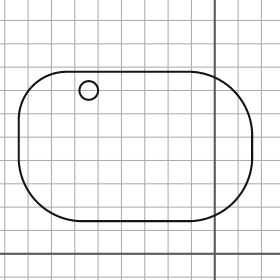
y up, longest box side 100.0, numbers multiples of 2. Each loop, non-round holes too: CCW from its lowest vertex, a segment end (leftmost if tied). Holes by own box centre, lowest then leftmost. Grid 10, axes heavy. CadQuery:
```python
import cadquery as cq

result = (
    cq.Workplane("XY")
    .moveTo(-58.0, 14.0)
    .lineTo(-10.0, 14.0)
    .threePointArc((8.0, 22.0), (16.0, 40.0))
    .lineTo(16.0, 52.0)
    .threePointArc((8.0, 70.0), (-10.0, 78.0))
    .lineTo(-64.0, 78.0)
    .threePointArc((-78.0, 72.0), (-84.0, 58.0))
    .lineTo(-84.0, 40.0)
    .threePointArc((-76.0, 22.0), (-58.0, 14.0))
    .close()
    .moveTo(-54.0, 70.0)
    .circle(4.0)
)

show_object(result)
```